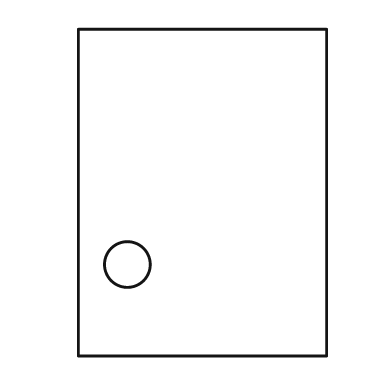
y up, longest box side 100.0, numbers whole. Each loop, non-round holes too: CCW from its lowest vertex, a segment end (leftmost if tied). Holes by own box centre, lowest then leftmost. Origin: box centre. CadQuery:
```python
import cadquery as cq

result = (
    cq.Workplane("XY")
    .moveTo(-38.0, -50.0)
    .lineTo(38.0, -50.0)
    .lineTo(38.0, 50.0)
    .lineTo(-38.0, 50.0)
    .close()
    .moveTo(-23.0, -22.0)
    .circle(7.0)
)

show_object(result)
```